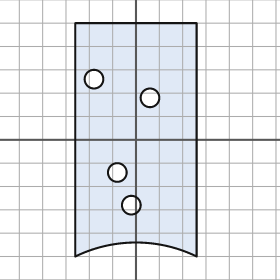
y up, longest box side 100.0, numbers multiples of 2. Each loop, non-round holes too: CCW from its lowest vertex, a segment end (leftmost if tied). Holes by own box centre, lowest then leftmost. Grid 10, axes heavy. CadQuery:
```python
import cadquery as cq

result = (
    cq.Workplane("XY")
    .moveTo(-26.0, -50.0)
    .threePointArc((0.0, -44.0), (26.0, -50.0))
    .lineTo(26.0, 50.0)
    .lineTo(-26.0, 50.0)
    .close()
    .moveTo(-2.0, -28.0)
    .circle(4.0)
    .moveTo(-8.0, -14.0)
    .circle(4.0)
    .moveTo(6.0, 18.0)
    .circle(4.0)
    .moveTo(-18.0, 26.0)
    .circle(4.0)
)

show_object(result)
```